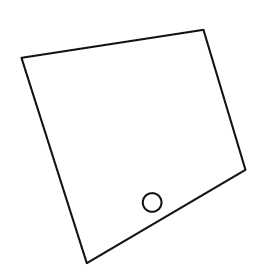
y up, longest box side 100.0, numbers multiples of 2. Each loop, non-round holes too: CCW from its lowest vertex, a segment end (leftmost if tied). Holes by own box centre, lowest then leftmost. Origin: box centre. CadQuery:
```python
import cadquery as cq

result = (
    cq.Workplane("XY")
    .moveTo(-20.0, -50.0)
    .lineTo(48.0, -10.0)
    .lineTo(30.0, 50.0)
    .lineTo(-48.0, 38.0)
    .close()
    .moveTo(8.0, -24.0)
    .circle(4.0)
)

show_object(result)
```